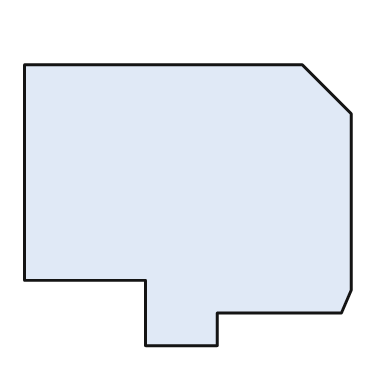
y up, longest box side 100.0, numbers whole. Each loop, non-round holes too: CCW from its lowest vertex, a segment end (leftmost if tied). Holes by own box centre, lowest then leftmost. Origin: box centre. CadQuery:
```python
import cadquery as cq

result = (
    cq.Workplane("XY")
    .moveTo(-13.0, -43.0)
    .lineTo(9.0, -43.0)
    .lineTo(9.0, -33.0)
    .lineTo(47.0, -33.0)
    .lineTo(50.0, -26.0)
    .lineTo(50.0, 28.0)
    .lineTo(35.0, 43.0)
    .lineTo(-50.0, 43.0)
    .lineTo(-50.0, -23.0)
    .lineTo(-13.0, -23.0)
    .close()
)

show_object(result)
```